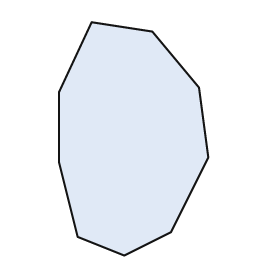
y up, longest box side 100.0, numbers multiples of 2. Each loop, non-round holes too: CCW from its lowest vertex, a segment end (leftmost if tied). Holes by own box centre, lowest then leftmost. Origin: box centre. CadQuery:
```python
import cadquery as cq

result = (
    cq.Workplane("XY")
    .moveTo(-4.0, -50.0)
    .lineTo(16.0, -40.0)
    .lineTo(32.0, -8.0)
    .lineTo(28.0, 22.0)
    .lineTo(8.0, 46.0)
    .lineTo(-18.0, 50.0)
    .lineTo(-32.0, 20.0)
    .lineTo(-32.0, -10.0)
    .lineTo(-24.0, -42.0)
    .close()
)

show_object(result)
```